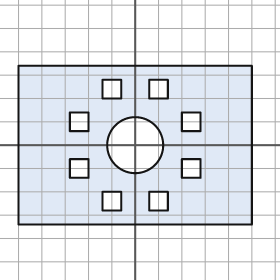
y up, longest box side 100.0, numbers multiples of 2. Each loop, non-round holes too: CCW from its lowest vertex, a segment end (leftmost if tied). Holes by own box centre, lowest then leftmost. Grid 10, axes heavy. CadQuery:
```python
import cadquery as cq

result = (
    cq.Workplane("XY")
    .moveTo(-50.0, -34.0)
    .lineTo(50.0, -34.0)
    .lineTo(50.0, 34.0)
    .lineTo(-50.0, 34.0)
    .close()
    .moveTo(-14.0, -28.0)
    .lineTo(-6.0, -28.0)
    .lineTo(-6.0, -20.0)
    .lineTo(-14.0, -20.0)
    .close()
    .moveTo(6.0, -28.0)
    .lineTo(14.0, -28.0)
    .lineTo(14.0, -20.0)
    .lineTo(6.0, -20.0)
    .close()
    .moveTo(-28.0, -14.0)
    .lineTo(-20.0, -14.0)
    .lineTo(-20.0, -6.0)
    .lineTo(-28.0, -6.0)
    .close()
    .moveTo(20.0, -14.0)
    .lineTo(28.0, -14.0)
    .lineTo(28.0, -6.0)
    .lineTo(20.0, -6.0)
    .close()
    .moveTo(0.0, 0.0)
    .circle(12.0)
    .moveTo(-28.0, 6.0)
    .lineTo(-20.0, 6.0)
    .lineTo(-20.0, 14.0)
    .lineTo(-28.0, 14.0)
    .close()
    .moveTo(20.0, 6.0)
    .lineTo(28.0, 6.0)
    .lineTo(28.0, 14.0)
    .lineTo(20.0, 14.0)
    .close()
    .moveTo(-14.0, 20.0)
    .lineTo(-6.0, 20.0)
    .lineTo(-6.0, 28.0)
    .lineTo(-14.0, 28.0)
    .close()
    .moveTo(6.0, 20.0)
    .lineTo(14.0, 20.0)
    .lineTo(14.0, 28.0)
    .lineTo(6.0, 28.0)
    .close()
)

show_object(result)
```